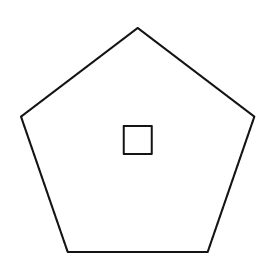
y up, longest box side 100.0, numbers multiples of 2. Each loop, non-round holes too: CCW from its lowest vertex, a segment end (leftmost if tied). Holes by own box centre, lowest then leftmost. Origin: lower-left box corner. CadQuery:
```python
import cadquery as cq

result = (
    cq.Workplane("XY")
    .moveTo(20.0, 0.0)
    .lineTo(80.0, 0.0)
    .lineTo(100.0, 58.0)
    .lineTo(50.0, 96.0)
    .lineTo(0.0, 58.0)
    .close()
    .moveTo(44.0, 42.0)
    .lineTo(56.0, 42.0)
    .lineTo(56.0, 54.0)
    .lineTo(44.0, 54.0)
    .close()
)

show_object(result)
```